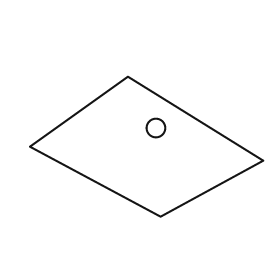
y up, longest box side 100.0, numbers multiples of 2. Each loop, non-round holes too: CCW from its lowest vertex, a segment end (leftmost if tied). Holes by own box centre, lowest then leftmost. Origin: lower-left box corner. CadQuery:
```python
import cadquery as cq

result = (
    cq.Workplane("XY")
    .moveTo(56.0, 0.0)
    .lineTo(100.0, 24.0)
    .lineTo(42.0, 60.0)
    .lineTo(0.0, 30.0)
    .close()
    .moveTo(54.0, 38.0)
    .circle(4.0)
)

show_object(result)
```